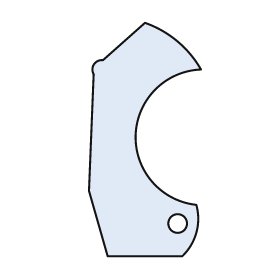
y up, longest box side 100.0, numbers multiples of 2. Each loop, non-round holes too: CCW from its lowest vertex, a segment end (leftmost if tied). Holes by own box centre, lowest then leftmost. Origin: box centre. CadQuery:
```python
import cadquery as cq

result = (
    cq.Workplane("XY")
    .moveTo(-16.0, -50.0)
    .lineTo(16.0, -50.0)
    .threePointArc((22.0, -40.0), (22.0, -28.0))
    .threePointArc((-4.0, 2.0), (24.0, 30.0))
    .threePointArc((14.0, 42.0), (0.0, 50.0))
    .lineTo(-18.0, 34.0)
    .threePointArc((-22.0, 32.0), (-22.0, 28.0))
    .lineTo(-24.0, -22.0)
    .close()
    .moveTo(14.0, -36.0)
    .circle(4.0)
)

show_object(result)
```